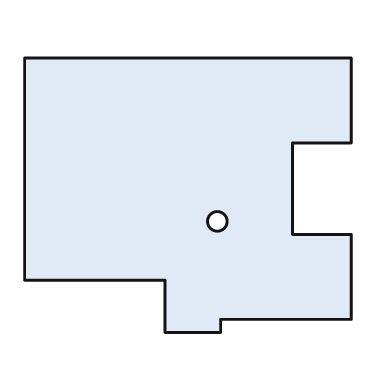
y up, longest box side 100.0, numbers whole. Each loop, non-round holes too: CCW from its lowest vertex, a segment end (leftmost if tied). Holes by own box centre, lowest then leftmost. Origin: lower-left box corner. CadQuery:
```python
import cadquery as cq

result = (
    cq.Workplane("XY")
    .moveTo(43.0, 0.0)
    .lineTo(60.0, 0.0)
    .lineTo(60.0, 4.0)
    .lineTo(100.0, 4.0)
    .lineTo(100.0, 30.0)
    .lineTo(82.0, 30.0)
    .lineTo(82.0, 58.0)
    .lineTo(100.0, 58.0)
    .lineTo(100.0, 84.0)
    .lineTo(0.0, 84.0)
    .lineTo(0.0, 16.0)
    .lineTo(43.0, 16.0)
    .close()
    .moveTo(59.0, 34.0)
    .circle(3.0)
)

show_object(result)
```